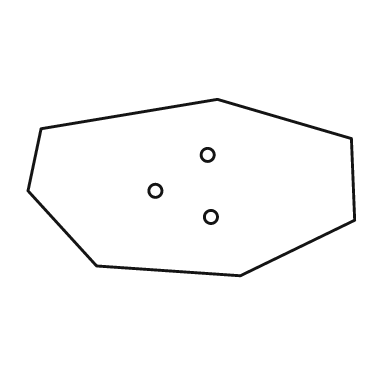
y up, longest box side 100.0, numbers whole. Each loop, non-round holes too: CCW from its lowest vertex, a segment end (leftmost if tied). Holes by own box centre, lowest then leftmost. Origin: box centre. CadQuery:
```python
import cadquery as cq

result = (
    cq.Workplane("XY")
    .moveTo(15.0, -27.0)
    .lineTo(50.0, -10.0)
    .lineTo(49.0, 15.0)
    .lineTo(8.0, 27.0)
    .lineTo(-46.0, 18.0)
    .lineTo(-50.0, -1.0)
    .lineTo(-29.0, -24.0)
    .close()
    .moveTo(6.0, -9.0)
    .circle(2.0)
    .moveTo(-11.0, -1.0)
    .circle(2.0)
    .moveTo(5.0, 10.0)
    .circle(2.0)
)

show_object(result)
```